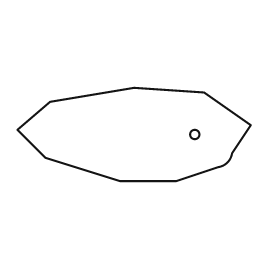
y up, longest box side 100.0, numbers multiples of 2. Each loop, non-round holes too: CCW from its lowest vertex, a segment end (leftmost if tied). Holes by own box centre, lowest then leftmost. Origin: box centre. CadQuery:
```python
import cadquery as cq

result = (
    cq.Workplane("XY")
    .moveTo(-6.0, -20.0)
    .lineTo(18.0, -20.0)
    .lineTo(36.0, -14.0)
    .threePointArc((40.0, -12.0), (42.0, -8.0))
    .lineTo(50.0, 4.0)
    .lineTo(30.0, 18.0)
    .lineTo(0.0, 20.0)
    .lineTo(-36.0, 14.0)
    .lineTo(-50.0, 2.0)
    .lineTo(-38.0, -10.0)
    .close()
    .moveTo(26.0, 0.0)
    .circle(2.0)
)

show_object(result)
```